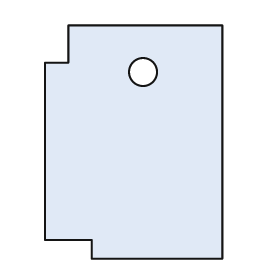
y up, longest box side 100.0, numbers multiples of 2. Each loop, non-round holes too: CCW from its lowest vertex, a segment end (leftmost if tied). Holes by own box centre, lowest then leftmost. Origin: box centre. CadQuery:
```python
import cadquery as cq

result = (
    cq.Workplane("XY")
    .moveTo(-18.0, -50.0)
    .lineTo(38.0, -50.0)
    .lineTo(38.0, 50.0)
    .lineTo(-28.0, 50.0)
    .lineTo(-28.0, 34.0)
    .lineTo(-38.0, 34.0)
    .lineTo(-38.0, -42.0)
    .lineTo(-18.0, -42.0)
    .close()
    .moveTo(4.0, 30.0)
    .circle(6.0)
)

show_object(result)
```